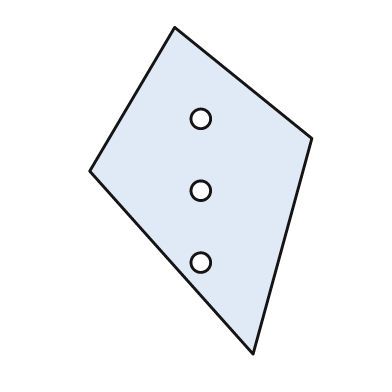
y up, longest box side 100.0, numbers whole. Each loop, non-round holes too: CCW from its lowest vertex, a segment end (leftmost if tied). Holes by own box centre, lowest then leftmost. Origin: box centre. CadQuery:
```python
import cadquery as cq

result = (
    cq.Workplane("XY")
    .moveTo(16.0, -50.0)
    .lineTo(34.0, 16.0)
    .lineTo(-8.0, 50.0)
    .lineTo(-34.0, 6.0)
    .close()
    .moveTo(0.0, -22.0)
    .circle(3.0)
    .moveTo(0.0, 0.0)
    .circle(3.0)
    .moveTo(0.0, 22.0)
    .circle(3.0)
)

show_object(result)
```